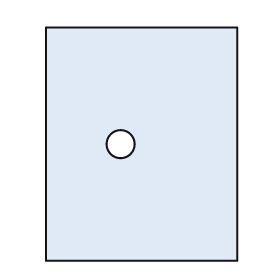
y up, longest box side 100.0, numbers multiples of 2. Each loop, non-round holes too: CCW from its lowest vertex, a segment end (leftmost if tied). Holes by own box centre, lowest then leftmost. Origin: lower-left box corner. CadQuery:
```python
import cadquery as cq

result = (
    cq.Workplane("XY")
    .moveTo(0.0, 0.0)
    .lineTo(82.0, 0.0)
    .lineTo(82.0, 100.0)
    .lineTo(0.0, 100.0)
    .close()
    .moveTo(32.0, 50.0)
    .circle(6.0)
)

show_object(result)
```